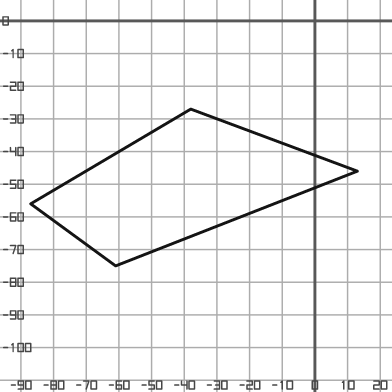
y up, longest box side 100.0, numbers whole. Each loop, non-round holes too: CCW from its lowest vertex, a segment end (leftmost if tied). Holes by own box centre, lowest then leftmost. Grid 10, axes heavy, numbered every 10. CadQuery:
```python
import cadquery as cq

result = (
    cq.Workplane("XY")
    .moveTo(-61.0, -75.0)
    .lineTo(13.0, -46.0)
    .lineTo(-38.0, -27.0)
    .lineTo(-87.0, -56.0)
    .close()
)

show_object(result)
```